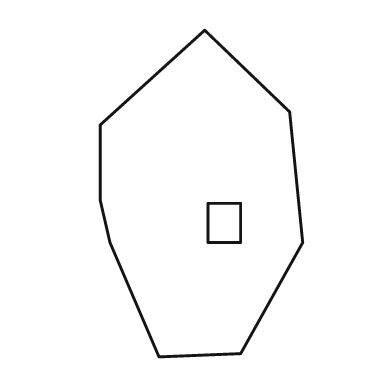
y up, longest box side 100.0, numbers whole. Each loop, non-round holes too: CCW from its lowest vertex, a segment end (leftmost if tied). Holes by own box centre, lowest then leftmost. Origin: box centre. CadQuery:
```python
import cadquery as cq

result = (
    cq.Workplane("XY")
    .moveTo(-13.0, -50.0)
    .lineTo(12.0, -49.0)
    .lineTo(31.0, -15.0)
    .lineTo(27.0, 25.0)
    .lineTo(1.0, 50.0)
    .lineTo(-31.0, 21.0)
    .lineTo(-31.0, -2.0)
    .lineTo(-28.0, -15.0)
    .close()
    .moveTo(2.0, -15.0)
    .lineTo(12.0, -15.0)
    .lineTo(12.0, -3.0)
    .lineTo(2.0, -3.0)
    .close()
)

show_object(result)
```